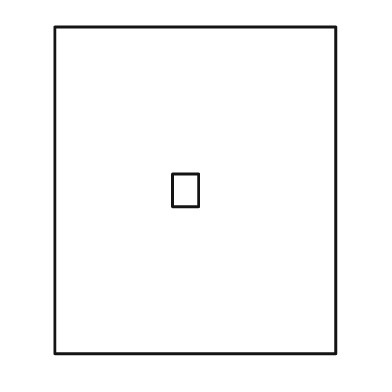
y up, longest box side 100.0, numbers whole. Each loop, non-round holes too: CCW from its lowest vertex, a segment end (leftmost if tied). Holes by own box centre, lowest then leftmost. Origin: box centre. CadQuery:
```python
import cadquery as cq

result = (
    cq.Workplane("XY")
    .moveTo(-43.0, -50.0)
    .lineTo(43.0, -50.0)
    .lineTo(43.0, 50.0)
    .lineTo(-43.0, 50.0)
    .close()
    .moveTo(-7.0, -5.0)
    .lineTo(1.0, -5.0)
    .lineTo(1.0, 5.0)
    .lineTo(-7.0, 5.0)
    .close()
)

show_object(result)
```